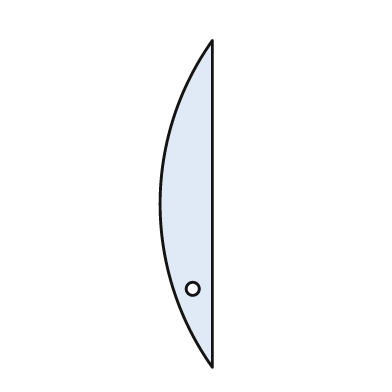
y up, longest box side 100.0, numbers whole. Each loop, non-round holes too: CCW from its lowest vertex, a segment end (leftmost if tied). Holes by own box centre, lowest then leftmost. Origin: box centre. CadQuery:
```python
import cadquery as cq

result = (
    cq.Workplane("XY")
    .moveTo(8.0, -50.0)
    .lineTo(8.0, 50.0)
    .threePointArc((-8.0, 0.0), (8.0, -50.0))
    .close()
    .moveTo(2.0, -26.0)
    .circle(2.0)
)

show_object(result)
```